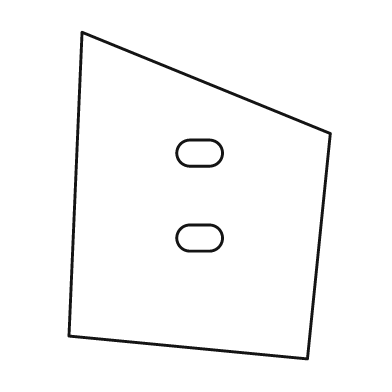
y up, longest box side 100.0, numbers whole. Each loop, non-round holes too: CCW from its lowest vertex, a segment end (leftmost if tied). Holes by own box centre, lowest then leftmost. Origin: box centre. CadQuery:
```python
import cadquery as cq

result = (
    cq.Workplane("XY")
    .moveTo(33.0, -50.0)
    .lineTo(40.0, 19.0)
    .lineTo(-36.0, 50.0)
    .lineTo(-40.0, -43.0)
    .close()
    .moveTo(-3.0, -17.0)
    .lineTo(3.0, -17.0)
    .threePointArc((7.0, -13.0), (3.0, -9.0))
    .lineTo(-3.0, -9.0)
    .threePointArc((-7.0, -13.0), (-3.0, -17.0))
    .close()
    .moveTo(-3.0, 9.0)
    .lineTo(3.0, 9.0)
    .threePointArc((7.0, 13.0), (3.0, 17.0))
    .lineTo(-3.0, 17.0)
    .threePointArc((-7.0, 13.0), (-3.0, 9.0))
    .close()
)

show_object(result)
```